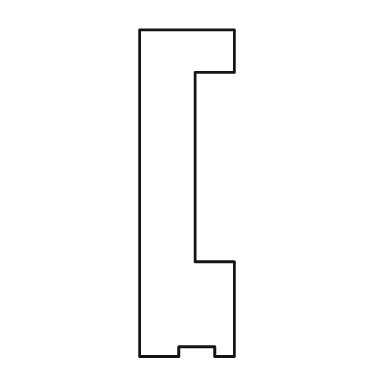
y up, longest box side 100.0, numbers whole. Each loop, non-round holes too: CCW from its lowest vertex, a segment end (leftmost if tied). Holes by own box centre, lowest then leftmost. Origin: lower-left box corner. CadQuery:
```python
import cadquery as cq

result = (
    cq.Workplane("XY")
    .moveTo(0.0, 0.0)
    .lineTo(12.0, 0.0)
    .lineTo(12.0, 3.0)
    .lineTo(23.0, 3.0)
    .lineTo(23.0, 0.0)
    .lineTo(29.0, 0.0)
    .lineTo(29.0, 29.0)
    .lineTo(17.0, 29.0)
    .lineTo(17.0, 87.0)
    .lineTo(29.0, 87.0)
    .lineTo(29.0, 100.0)
    .lineTo(0.0, 100.0)
    .close()
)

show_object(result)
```